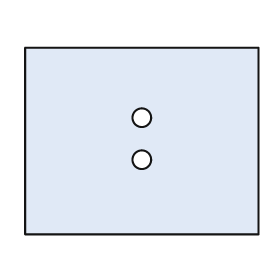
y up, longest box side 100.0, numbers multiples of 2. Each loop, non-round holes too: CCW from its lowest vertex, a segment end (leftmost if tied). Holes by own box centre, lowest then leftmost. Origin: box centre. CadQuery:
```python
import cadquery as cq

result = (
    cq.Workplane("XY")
    .moveTo(-50.0, -40.0)
    .lineTo(50.0, -40.0)
    .lineTo(50.0, 40.0)
    .lineTo(-50.0, 40.0)
    .close()
    .moveTo(0.0, -8.0)
    .circle(4.0)
    .moveTo(0.0, 10.0)
    .circle(4.0)
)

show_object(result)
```